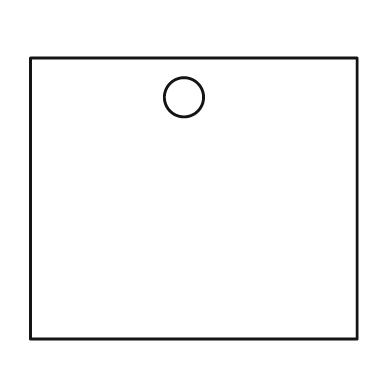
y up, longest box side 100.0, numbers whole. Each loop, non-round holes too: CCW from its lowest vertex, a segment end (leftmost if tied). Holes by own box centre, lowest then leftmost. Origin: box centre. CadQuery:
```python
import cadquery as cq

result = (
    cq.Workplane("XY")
    .moveTo(-50.0, -43.0)
    .lineTo(50.0, -43.0)
    .lineTo(50.0, 43.0)
    .lineTo(-50.0, 43.0)
    .close()
    .moveTo(-3.0, 31.0)
    .circle(6.0)
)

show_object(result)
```